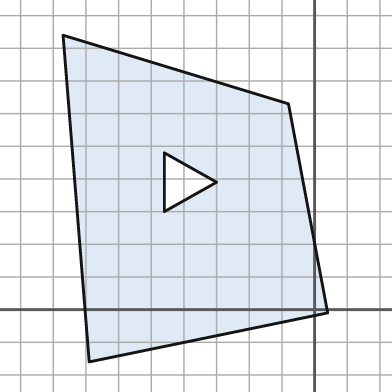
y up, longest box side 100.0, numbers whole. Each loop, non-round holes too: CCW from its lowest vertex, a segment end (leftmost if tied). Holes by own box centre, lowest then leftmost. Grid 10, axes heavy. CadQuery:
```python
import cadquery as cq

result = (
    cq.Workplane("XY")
    .moveTo(-69.0, -16.0)
    .lineTo(4.0, -1.0)
    .lineTo(-8.0, 63.0)
    .lineTo(-77.0, 84.0)
    .close()
    .moveTo(-46.0, 30.0)
    .lineTo(-30.0, 39.0)
    .lineTo(-46.0, 48.0)
    .close()
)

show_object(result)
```